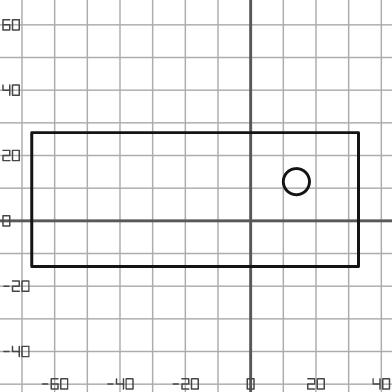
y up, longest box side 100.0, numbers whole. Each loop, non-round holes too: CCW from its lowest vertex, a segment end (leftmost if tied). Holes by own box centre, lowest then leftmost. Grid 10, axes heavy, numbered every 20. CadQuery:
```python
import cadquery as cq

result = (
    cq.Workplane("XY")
    .moveTo(-67.0, -14.0)
    .lineTo(33.0, -14.0)
    .lineTo(33.0, 27.0)
    .lineTo(-67.0, 27.0)
    .close()
    .moveTo(14.0, 12.0)
    .circle(4.0)
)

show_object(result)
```